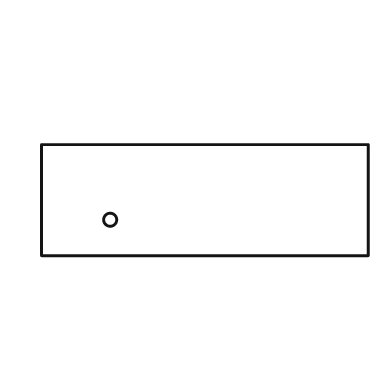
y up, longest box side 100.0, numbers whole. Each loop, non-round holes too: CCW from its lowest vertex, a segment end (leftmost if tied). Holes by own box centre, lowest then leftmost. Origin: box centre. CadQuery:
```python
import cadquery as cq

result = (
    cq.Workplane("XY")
    .moveTo(-50.0, -17.0)
    .lineTo(50.0, -17.0)
    .lineTo(50.0, 17.0)
    .lineTo(-50.0, 17.0)
    .close()
    .moveTo(-29.0, -6.0)
    .circle(2.0)
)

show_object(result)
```